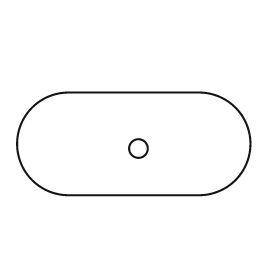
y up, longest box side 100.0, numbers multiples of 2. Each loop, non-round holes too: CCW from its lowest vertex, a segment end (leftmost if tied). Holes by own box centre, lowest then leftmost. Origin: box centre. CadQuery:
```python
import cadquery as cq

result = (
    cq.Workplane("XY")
    .moveTo(-28.0, -22.0)
    .lineTo(28.0, -22.0)
    .threePointArc((50.0, 0.0), (28.0, 22.0))
    .lineTo(-28.0, 22.0)
    .threePointArc((-50.0, 0.0), (-28.0, -22.0))
    .close()
    .moveTo(2.0, -2.0)
    .circle(4.0)
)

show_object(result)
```